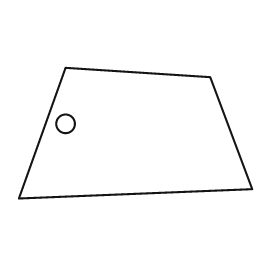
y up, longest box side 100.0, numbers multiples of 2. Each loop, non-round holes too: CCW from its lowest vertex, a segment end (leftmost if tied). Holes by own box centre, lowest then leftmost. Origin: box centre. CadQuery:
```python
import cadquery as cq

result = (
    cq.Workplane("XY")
    .moveTo(-50.0, -28.0)
    .lineTo(50.0, -24.0)
    .lineTo(32.0, 24.0)
    .lineTo(-30.0, 28.0)
    .close()
    .moveTo(-30.0, 4.0)
    .circle(4.0)
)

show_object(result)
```